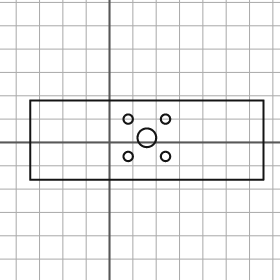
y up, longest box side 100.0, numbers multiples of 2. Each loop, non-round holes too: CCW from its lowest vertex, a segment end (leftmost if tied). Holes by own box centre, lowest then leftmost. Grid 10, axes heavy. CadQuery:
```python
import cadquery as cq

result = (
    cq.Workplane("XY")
    .moveTo(-34.0, -16.0)
    .lineTo(66.0, -16.0)
    .lineTo(66.0, 18.0)
    .lineTo(-34.0, 18.0)
    .close()
    .moveTo(8.0, -6.0)
    .circle(2.0)
    .moveTo(24.0, -6.0)
    .circle(2.0)
    .moveTo(16.0, 2.0)
    .circle(4.0)
    .moveTo(8.0, 10.0)
    .circle(2.0)
    .moveTo(24.0, 10.0)
    .circle(2.0)
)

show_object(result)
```